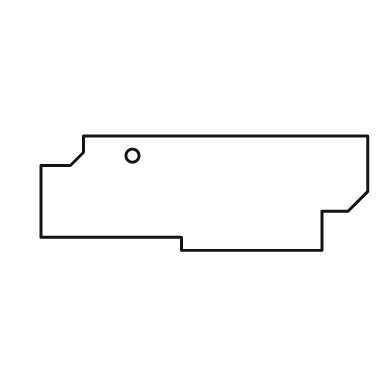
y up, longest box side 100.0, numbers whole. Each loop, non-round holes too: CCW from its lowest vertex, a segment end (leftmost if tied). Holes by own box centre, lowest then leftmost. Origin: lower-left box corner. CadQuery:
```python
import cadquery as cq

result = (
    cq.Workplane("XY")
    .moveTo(43.0, 0.0)
    .lineTo(86.0, 0.0)
    .lineTo(86.0, 12.0)
    .lineTo(94.0, 12.0)
    .lineTo(100.0, 18.0)
    .lineTo(100.0, 35.0)
    .lineTo(13.0, 35.0)
    .lineTo(13.0, 30.0)
    .lineTo(9.0, 26.0)
    .lineTo(0.0, 26.0)
    .lineTo(0.0, 4.0)
    .lineTo(43.0, 4.0)
    .close()
    .moveTo(28.0, 29.0)
    .circle(2.0)
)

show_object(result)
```